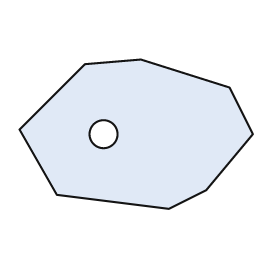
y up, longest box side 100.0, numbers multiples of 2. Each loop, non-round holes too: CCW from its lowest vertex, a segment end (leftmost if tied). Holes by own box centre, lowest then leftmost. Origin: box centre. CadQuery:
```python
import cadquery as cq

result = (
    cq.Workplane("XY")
    .moveTo(14.0, -32.0)
    .lineTo(30.0, -24.0)
    .lineTo(50.0, 0.0)
    .lineTo(40.0, 20.0)
    .lineTo(2.0, 32.0)
    .lineTo(-22.0, 30.0)
    .lineTo(-50.0, 2.0)
    .lineTo(-34.0, -26.0)
    .close()
    .moveTo(-14.0, 0.0)
    .circle(6.0)
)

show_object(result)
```